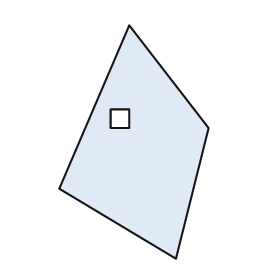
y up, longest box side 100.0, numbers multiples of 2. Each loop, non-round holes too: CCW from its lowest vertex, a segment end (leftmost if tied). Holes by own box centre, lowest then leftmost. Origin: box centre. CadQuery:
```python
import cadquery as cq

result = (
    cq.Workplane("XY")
    .moveTo(18.0, -50.0)
    .lineTo(32.0, 6.0)
    .lineTo(-2.0, 50.0)
    .lineTo(-32.0, -20.0)
    .close()
    .moveTo(-10.0, 6.0)
    .lineTo(-2.0, 6.0)
    .lineTo(-2.0, 14.0)
    .lineTo(-10.0, 14.0)
    .close()
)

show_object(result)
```